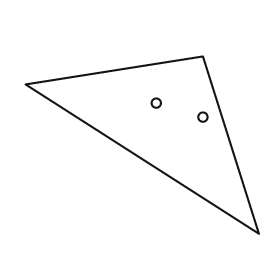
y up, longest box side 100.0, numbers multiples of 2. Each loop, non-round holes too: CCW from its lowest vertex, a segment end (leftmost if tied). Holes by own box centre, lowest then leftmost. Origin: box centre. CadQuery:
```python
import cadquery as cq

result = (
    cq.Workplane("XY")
    .moveTo(50.0, -38.0)
    .lineTo(26.0, 38.0)
    .lineTo(-50.0, 26.0)
    .close()
    .moveTo(26.0, 12.0)
    .circle(2.0)
    .moveTo(6.0, 18.0)
    .circle(2.0)
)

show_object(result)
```